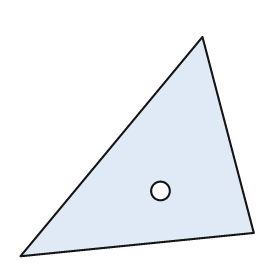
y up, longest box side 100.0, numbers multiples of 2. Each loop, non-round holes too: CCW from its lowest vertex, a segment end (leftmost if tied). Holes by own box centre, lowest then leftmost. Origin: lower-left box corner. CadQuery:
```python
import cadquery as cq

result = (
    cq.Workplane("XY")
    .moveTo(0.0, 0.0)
    .lineTo(100.0, 10.0)
    .lineTo(78.0, 94.0)
    .close()
    .moveTo(60.0, 28.0)
    .circle(4.0)
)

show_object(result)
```